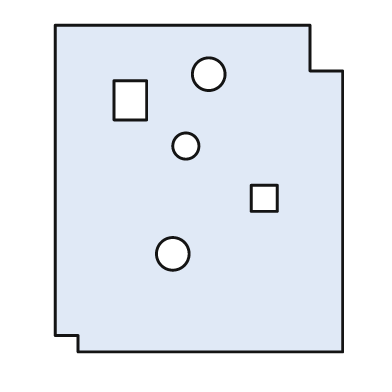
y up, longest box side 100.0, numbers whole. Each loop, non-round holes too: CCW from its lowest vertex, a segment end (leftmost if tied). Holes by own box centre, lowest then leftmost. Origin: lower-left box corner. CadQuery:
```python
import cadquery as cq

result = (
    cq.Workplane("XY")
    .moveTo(7.0, 0.0)
    .lineTo(88.0, 0.0)
    .lineTo(88.0, 86.0)
    .lineTo(78.0, 86.0)
    .lineTo(78.0, 100.0)
    .lineTo(0.0, 100.0)
    .lineTo(0.0, 5.0)
    .lineTo(7.0, 5.0)
    .close()
    .moveTo(36.0, 30.0)
    .circle(5.0)
    .moveTo(60.0, 43.0)
    .lineTo(68.0, 43.0)
    .lineTo(68.0, 51.0)
    .lineTo(60.0, 51.0)
    .close()
    .moveTo(40.0, 63.0)
    .circle(4.0)
    .moveTo(18.0, 71.0)
    .lineTo(28.0, 71.0)
    .lineTo(28.0, 83.0)
    .lineTo(18.0, 83.0)
    .close()
    .moveTo(47.0, 85.0)
    .circle(5.0)
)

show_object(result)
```